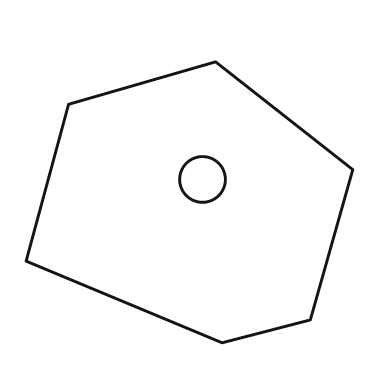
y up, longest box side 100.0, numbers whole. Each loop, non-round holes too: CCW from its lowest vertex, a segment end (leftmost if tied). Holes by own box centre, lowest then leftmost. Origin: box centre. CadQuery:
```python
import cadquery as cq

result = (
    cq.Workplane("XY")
    .moveTo(10.0, -43.0)
    .lineTo(37.0, -36.0)
    .lineTo(50.0, 10.0)
    .lineTo(8.0, 43.0)
    .lineTo(-37.0, 30.0)
    .lineTo(-50.0, -18.0)
    .close()
    .moveTo(4.0, 7.0)
    .circle(7.0)
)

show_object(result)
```